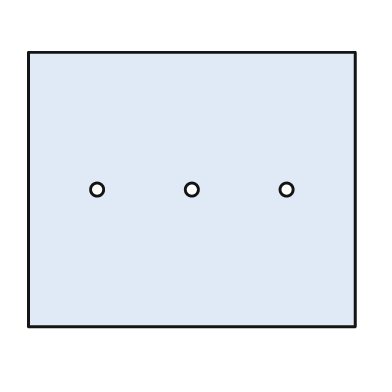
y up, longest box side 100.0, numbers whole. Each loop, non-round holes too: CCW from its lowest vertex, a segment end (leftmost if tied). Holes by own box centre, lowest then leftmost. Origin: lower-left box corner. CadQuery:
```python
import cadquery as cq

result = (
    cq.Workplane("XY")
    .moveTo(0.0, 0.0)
    .lineTo(100.0, 0.0)
    .lineTo(100.0, 84.0)
    .lineTo(0.0, 84.0)
    .close()
    .moveTo(21.0, 42.0)
    .circle(2.0)
    .moveTo(50.0, 42.0)
    .circle(2.0)
    .moveTo(79.0, 42.0)
    .circle(2.0)
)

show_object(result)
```